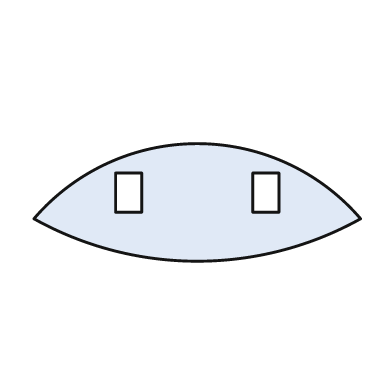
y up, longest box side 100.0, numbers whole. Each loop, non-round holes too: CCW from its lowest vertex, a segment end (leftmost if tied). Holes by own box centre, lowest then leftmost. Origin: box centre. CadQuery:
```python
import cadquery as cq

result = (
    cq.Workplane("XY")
    .moveTo(-50.0, -5.0)
    .threePointArc((0.0, -18.0), (50.0, -5.0))
    .threePointArc((0.0, 18.0), (-50.0, -5.0))
    .close()
    .moveTo(-25.0, -3.0)
    .lineTo(-17.0, -3.0)
    .lineTo(-17.0, 9.0)
    .lineTo(-25.0, 9.0)
    .close()
    .moveTo(17.0, -3.0)
    .lineTo(25.0, -3.0)
    .lineTo(25.0, 9.0)
    .lineTo(17.0, 9.0)
    .close()
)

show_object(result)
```